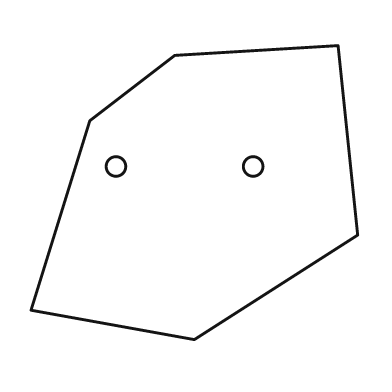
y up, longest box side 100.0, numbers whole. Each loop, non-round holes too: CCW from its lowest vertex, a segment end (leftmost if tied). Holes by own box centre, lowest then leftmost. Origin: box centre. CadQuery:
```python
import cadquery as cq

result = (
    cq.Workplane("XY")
    .moveTo(0.0, -45.0)
    .lineTo(50.0, -13.0)
    .lineTo(44.0, 45.0)
    .lineTo(-6.0, 42.0)
    .lineTo(-32.0, 22.0)
    .lineTo(-50.0, -36.0)
    .close()
    .moveTo(-24.0, 8.0)
    .circle(3.0)
    .moveTo(18.0, 8.0)
    .circle(3.0)
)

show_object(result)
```